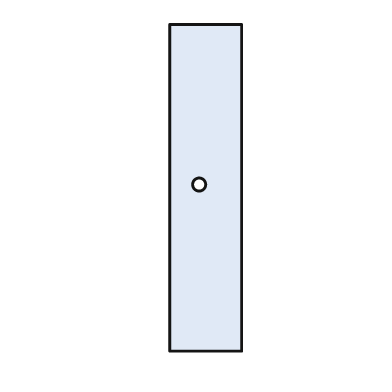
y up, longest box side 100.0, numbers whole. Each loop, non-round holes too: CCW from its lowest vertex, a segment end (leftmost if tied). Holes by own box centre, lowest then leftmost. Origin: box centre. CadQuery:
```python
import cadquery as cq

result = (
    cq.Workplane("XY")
    .moveTo(-11.0, -50.0)
    .lineTo(11.0, -50.0)
    .lineTo(11.0, 50.0)
    .lineTo(-11.0, 50.0)
    .close()
    .moveTo(-2.0, 1.0)
    .circle(2.0)
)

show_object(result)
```